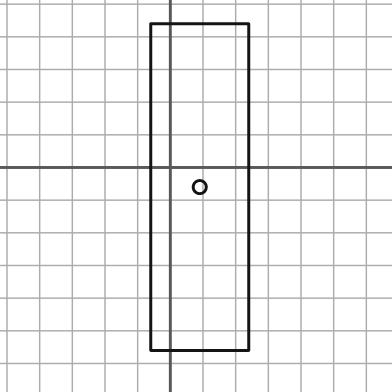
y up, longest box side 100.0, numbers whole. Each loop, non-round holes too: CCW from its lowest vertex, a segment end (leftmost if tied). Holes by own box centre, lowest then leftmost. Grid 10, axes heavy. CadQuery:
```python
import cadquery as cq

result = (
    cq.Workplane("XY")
    .moveTo(-6.0, -56.0)
    .lineTo(24.0, -56.0)
    .lineTo(24.0, 44.0)
    .lineTo(-6.0, 44.0)
    .close()
    .moveTo(9.0, -6.0)
    .circle(2.0)
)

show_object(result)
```